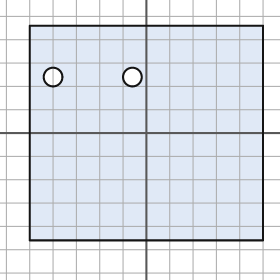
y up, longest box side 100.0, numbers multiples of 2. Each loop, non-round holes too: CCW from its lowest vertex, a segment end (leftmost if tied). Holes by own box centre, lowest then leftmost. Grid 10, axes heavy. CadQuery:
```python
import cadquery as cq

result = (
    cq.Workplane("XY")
    .moveTo(-50.0, -46.0)
    .lineTo(50.0, -46.0)
    .lineTo(50.0, 46.0)
    .lineTo(-50.0, 46.0)
    .close()
    .moveTo(-40.0, 24.0)
    .circle(4.0)
    .moveTo(-6.0, 24.0)
    .circle(4.0)
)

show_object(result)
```